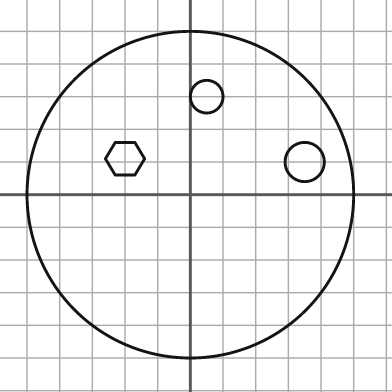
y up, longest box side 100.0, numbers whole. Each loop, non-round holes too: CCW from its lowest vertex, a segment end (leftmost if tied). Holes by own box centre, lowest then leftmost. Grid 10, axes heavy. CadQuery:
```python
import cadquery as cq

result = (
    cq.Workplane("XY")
    .moveTo(0.0, 0.0)
    .circle(50.0)
    .moveTo(35.0, 10.0)
    .circle(6.0)
    .moveTo(-23.0, 6.0)
    .lineTo(-17.0, 6.0)
    .lineTo(-14.0, 11.0)
    .lineTo(-17.0, 16.0)
    .lineTo(-23.0, 16.0)
    .lineTo(-26.0, 11.0)
    .close()
    .moveTo(5.0, 30.0)
    .circle(5.0)
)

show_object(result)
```